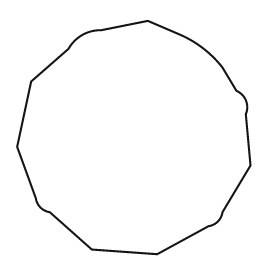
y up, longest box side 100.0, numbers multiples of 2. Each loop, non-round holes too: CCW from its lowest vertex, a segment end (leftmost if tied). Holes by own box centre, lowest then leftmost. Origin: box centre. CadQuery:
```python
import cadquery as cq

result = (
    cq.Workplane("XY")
    .moveTo(10.0, -50.0)
    .lineTo(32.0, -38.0)
    .threePointArc((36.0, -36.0), (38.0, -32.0))
    .lineTo(50.0, -12.0)
    .lineTo(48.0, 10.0)
    .threePointArc((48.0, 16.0), (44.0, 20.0))
    .lineTo(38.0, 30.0)
    .threePointArc((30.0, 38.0), (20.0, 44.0))
    .lineTo(6.0, 50.0)
    .lineTo(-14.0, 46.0)
    .threePointArc((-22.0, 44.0), (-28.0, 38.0))
    .lineTo(-44.0, 24.0)
    .lineTo(-50.0, -4.0)
    .lineTo(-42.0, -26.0)
    .threePointArc((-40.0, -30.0), (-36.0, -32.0))
    .lineTo(-18.0, -48.0)
    .close()
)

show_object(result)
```